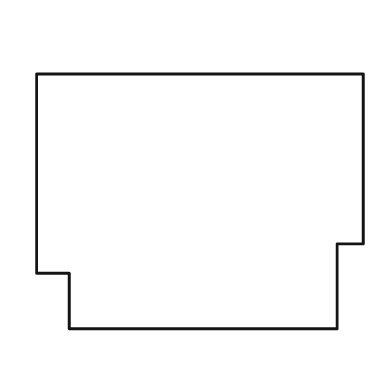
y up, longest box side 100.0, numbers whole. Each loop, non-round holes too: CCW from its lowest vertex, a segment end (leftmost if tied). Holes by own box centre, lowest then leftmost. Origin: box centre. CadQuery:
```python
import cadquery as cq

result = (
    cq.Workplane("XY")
    .moveTo(-40.0, -39.0)
    .lineTo(42.0, -39.0)
    .lineTo(42.0, -13.0)
    .lineTo(50.0, -13.0)
    .lineTo(50.0, 39.0)
    .lineTo(-50.0, 39.0)
    .lineTo(-50.0, -22.0)
    .lineTo(-40.0, -22.0)
    .close()
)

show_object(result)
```